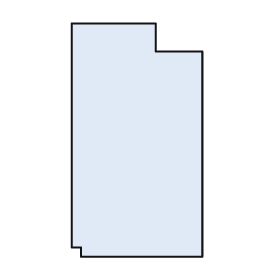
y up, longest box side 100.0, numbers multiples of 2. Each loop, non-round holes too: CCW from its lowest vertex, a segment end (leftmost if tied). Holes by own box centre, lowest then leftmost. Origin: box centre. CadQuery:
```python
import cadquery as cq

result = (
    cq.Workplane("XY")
    .moveTo(-24.0, -50.0)
    .lineTo(28.0, -50.0)
    .lineTo(28.0, 38.0)
    .lineTo(8.0, 38.0)
    .lineTo(8.0, 50.0)
    .lineTo(-28.0, 50.0)
    .lineTo(-28.0, -46.0)
    .lineTo(-24.0, -46.0)
    .close()
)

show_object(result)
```